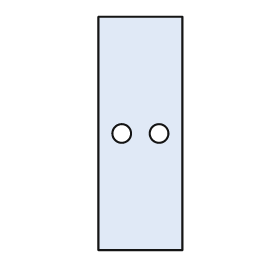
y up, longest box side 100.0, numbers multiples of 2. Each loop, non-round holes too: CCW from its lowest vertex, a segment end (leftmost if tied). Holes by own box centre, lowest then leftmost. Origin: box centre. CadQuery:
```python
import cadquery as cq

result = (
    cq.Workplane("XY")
    .moveTo(-18.0, -50.0)
    .lineTo(18.0, -50.0)
    .lineTo(18.0, 50.0)
    .lineTo(-18.0, 50.0)
    .close()
    .moveTo(-8.0, 0.0)
    .circle(4.0)
    .moveTo(8.0, 0.0)
    .circle(4.0)
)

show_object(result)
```